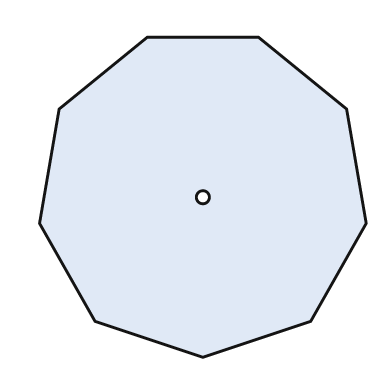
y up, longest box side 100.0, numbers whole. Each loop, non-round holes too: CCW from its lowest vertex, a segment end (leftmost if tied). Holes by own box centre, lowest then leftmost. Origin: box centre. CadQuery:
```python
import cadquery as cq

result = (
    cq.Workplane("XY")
    .moveTo(0.0, -49.0)
    .lineTo(33.0, -38.0)
    .lineTo(50.0, -8.0)
    .lineTo(44.0, 27.0)
    .lineTo(17.0, 49.0)
    .lineTo(-17.0, 49.0)
    .lineTo(-44.0, 27.0)
    .lineTo(-50.0, -8.0)
    .lineTo(-33.0, -38.0)
    .close()
    .moveTo(0.0, 0.0)
    .circle(2.0)
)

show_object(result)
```